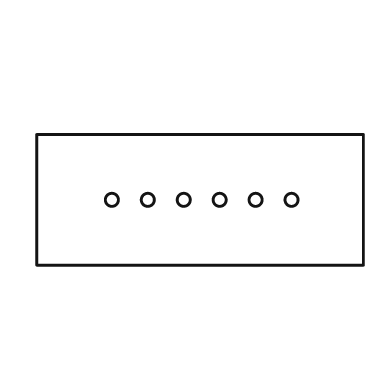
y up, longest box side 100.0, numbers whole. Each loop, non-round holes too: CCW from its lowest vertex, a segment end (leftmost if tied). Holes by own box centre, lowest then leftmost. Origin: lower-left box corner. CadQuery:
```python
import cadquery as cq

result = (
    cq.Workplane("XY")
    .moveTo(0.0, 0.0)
    .lineTo(100.0, 0.0)
    .lineTo(100.0, 40.0)
    .lineTo(0.0, 40.0)
    .close()
    .moveTo(23.0, 20.0)
    .circle(2.0)
    .moveTo(34.0, 20.0)
    .circle(2.0)
    .moveTo(45.0, 20.0)
    .circle(2.0)
    .moveTo(56.0, 20.0)
    .circle(2.0)
    .moveTo(67.0, 20.0)
    .circle(2.0)
    .moveTo(78.0, 20.0)
    .circle(2.0)
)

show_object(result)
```